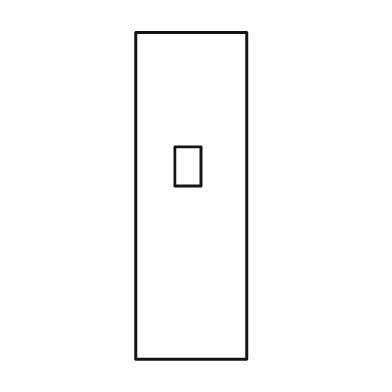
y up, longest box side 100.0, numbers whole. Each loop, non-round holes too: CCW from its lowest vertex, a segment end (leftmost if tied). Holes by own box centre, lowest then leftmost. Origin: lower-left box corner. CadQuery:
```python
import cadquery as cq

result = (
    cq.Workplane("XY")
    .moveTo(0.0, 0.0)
    .lineTo(34.0, 0.0)
    .lineTo(34.0, 100.0)
    .lineTo(0.0, 100.0)
    .close()
    .moveTo(12.0, 53.0)
    .lineTo(20.0, 53.0)
    .lineTo(20.0, 65.0)
    .lineTo(12.0, 65.0)
    .close()
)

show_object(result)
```